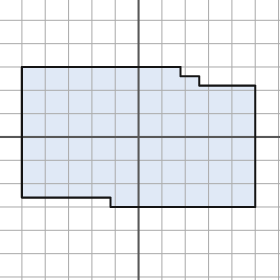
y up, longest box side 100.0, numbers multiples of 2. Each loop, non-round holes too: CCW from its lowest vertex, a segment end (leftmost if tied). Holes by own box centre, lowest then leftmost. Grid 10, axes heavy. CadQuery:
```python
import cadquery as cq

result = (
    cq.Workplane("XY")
    .moveTo(-12.0, -30.0)
    .lineTo(50.0, -30.0)
    .lineTo(50.0, 22.0)
    .lineTo(26.0, 22.0)
    .lineTo(26.0, 26.0)
    .lineTo(18.0, 26.0)
    .lineTo(18.0, 30.0)
    .lineTo(-50.0, 30.0)
    .lineTo(-50.0, -26.0)
    .lineTo(-12.0, -26.0)
    .close()
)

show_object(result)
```